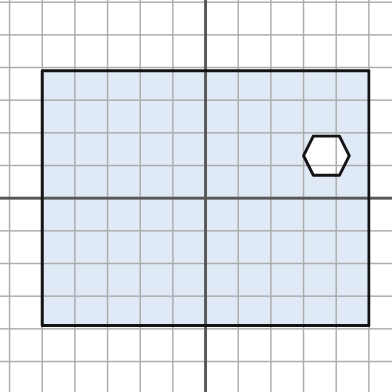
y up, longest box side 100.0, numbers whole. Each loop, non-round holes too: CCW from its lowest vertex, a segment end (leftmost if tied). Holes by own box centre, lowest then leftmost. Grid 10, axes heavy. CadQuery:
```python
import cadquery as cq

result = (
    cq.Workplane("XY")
    .moveTo(-50.0, -39.0)
    .lineTo(50.0, -39.0)
    .lineTo(50.0, 39.0)
    .lineTo(-50.0, 39.0)
    .close()
    .moveTo(33.0, 7.0)
    .lineTo(41.0, 7.0)
    .lineTo(44.0, 13.0)
    .lineTo(41.0, 19.0)
    .lineTo(33.0, 19.0)
    .lineTo(30.0, 13.0)
    .close()
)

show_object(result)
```